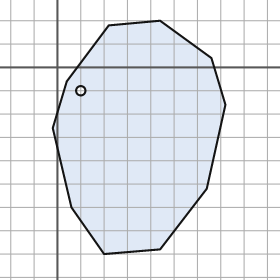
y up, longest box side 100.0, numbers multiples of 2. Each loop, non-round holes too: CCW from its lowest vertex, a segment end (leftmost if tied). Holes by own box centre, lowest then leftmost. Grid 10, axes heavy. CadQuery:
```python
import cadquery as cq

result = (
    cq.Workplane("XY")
    .moveTo(20.0, -80.0)
    .lineTo(44.0, -78.0)
    .lineTo(64.0, -52.0)
    .lineTo(72.0, -16.0)
    .lineTo(66.0, 4.0)
    .lineTo(44.0, 20.0)
    .lineTo(22.0, 18.0)
    .lineTo(4.0, -6.0)
    .lineTo(-2.0, -26.0)
    .lineTo(6.0, -60.0)
    .close()
    .moveTo(10.0, -10.0)
    .circle(2.0)
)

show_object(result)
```